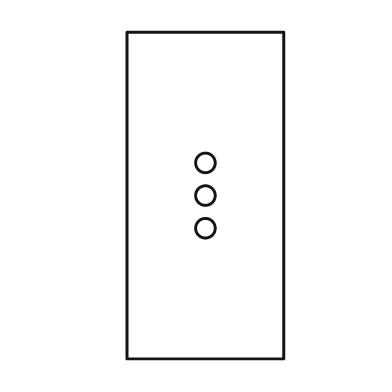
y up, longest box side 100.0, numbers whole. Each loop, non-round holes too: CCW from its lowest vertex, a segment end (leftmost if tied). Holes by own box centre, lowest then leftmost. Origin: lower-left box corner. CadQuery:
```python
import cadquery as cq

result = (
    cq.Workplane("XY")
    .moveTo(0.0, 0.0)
    .lineTo(48.0, 0.0)
    .lineTo(48.0, 100.0)
    .lineTo(0.0, 100.0)
    .close()
    .moveTo(24.0, 40.0)
    .circle(3.0)
    .moveTo(24.0, 50.0)
    .circle(3.0)
    .moveTo(24.0, 60.0)
    .circle(3.0)
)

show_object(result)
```